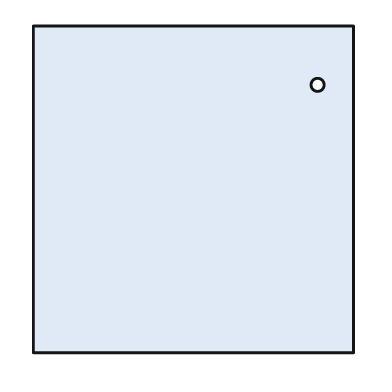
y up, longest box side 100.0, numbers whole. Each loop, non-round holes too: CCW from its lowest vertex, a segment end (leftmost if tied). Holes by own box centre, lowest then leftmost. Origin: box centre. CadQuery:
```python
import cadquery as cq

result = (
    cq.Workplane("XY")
    .moveTo(-49.0, -50.0)
    .lineTo(49.0, -50.0)
    .lineTo(49.0, 50.0)
    .lineTo(-49.0, 50.0)
    .close()
    .moveTo(38.0, 32.0)
    .circle(2.0)
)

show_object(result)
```